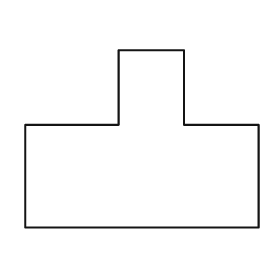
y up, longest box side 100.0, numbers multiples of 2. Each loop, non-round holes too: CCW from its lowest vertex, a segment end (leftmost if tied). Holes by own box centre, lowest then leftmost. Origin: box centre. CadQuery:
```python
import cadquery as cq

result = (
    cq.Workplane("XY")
    .moveTo(-50.0, -38.0)
    .lineTo(50.0, -38.0)
    .lineTo(50.0, 6.0)
    .lineTo(18.0, 6.0)
    .lineTo(18.0, 38.0)
    .lineTo(-10.0, 38.0)
    .lineTo(-10.0, 6.0)
    .lineTo(-50.0, 6.0)
    .close()
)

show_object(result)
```